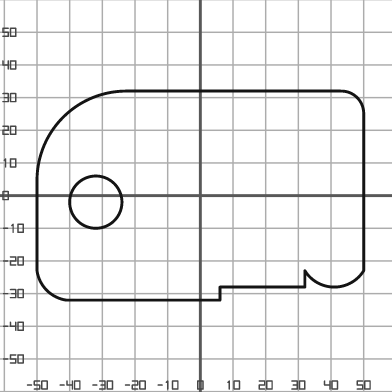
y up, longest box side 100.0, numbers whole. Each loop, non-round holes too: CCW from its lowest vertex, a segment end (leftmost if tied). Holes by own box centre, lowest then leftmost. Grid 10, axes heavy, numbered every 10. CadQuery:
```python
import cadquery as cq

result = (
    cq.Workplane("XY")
    .moveTo(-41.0, -32.0)
    .lineTo(6.0, -32.0)
    .lineTo(6.0, -28.0)
    .lineTo(32.0, -28.0)
    .lineTo(32.0, -23.0)
    .threePointArc((41.0, -28.0), (50.0, -23.0))
    .lineTo(50.0, 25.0)
    .threePointArc((48.0, 30.0), (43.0, 32.0))
    .lineTo(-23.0, 32.0)
    .threePointArc((-42.0, 24.0), (-50.0, 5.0))
    .lineTo(-50.0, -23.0)
    .threePointArc((-47.0, -29.0), (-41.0, -32.0))
    .close()
    .moveTo(-32.0, -2.0)
    .circle(8.0)
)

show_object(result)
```